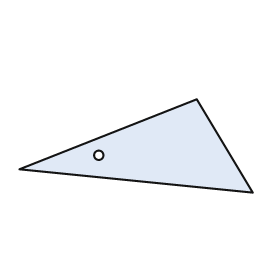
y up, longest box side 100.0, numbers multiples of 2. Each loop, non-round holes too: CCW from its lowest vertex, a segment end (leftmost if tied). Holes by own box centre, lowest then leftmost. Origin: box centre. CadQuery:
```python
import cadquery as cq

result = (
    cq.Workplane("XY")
    .moveTo(50.0, -20.0)
    .lineTo(26.0, 20.0)
    .lineTo(-50.0, -10.0)
    .close()
    .moveTo(-16.0, -4.0)
    .circle(2.0)
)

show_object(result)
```